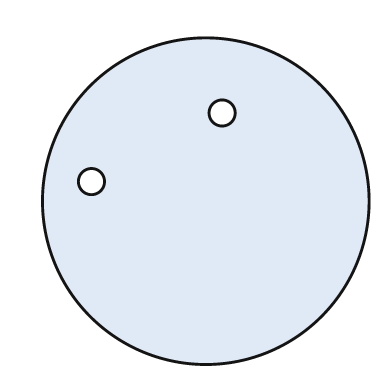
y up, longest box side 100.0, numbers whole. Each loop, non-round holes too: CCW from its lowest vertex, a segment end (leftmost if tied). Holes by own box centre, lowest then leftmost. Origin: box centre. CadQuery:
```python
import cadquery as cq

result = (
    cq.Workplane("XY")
    .moveTo(0.0, 0.0)
    .circle(50.0)
    .moveTo(-35.0, 6.0)
    .circle(4.0)
    .moveTo(5.0, 27.0)
    .circle(4.0)
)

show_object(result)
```